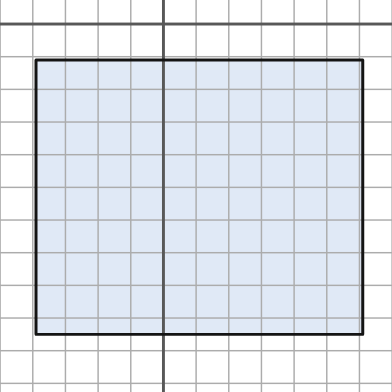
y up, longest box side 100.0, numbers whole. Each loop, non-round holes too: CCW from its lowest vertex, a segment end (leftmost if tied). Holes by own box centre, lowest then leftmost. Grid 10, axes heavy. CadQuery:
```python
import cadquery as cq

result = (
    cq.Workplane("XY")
    .moveTo(-39.0, -95.0)
    .lineTo(61.0, -95.0)
    .lineTo(61.0, -11.0)
    .lineTo(-39.0, -11.0)
    .close()
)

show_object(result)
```